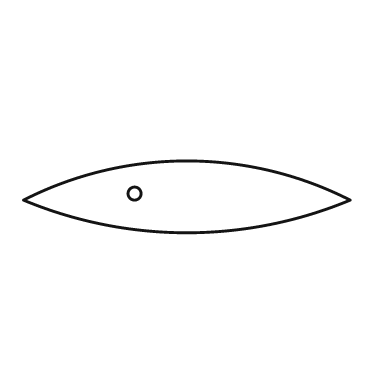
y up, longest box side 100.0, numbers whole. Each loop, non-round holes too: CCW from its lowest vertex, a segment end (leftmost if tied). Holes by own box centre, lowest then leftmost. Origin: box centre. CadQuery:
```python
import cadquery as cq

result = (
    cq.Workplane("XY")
    .moveTo(-50.0, -1.0)
    .threePointArc((0.0, -11.0), (50.0, -1.0))
    .threePointArc((0.0, 11.0), (-50.0, -1.0))
    .close()
    .moveTo(-16.0, 1.0)
    .circle(2.0)
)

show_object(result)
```